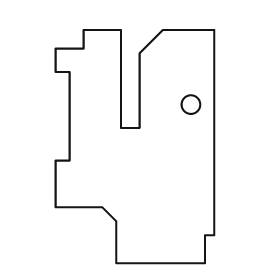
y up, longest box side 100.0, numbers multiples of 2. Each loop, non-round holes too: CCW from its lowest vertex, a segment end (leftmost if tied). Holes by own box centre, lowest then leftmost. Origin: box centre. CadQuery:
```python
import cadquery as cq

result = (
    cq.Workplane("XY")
    .moveTo(-8.0, -50.0)
    .lineTo(30.0, -50.0)
    .lineTo(30.0, -38.0)
    .lineTo(34.0, -38.0)
    .lineTo(34.0, 50.0)
    .lineTo(12.0, 50.0)
    .lineTo(2.0, 40.0)
    .lineTo(2.0, 8.0)
    .lineTo(-6.0, 8.0)
    .lineTo(-6.0, 50.0)
    .lineTo(-22.0, 50.0)
    .lineTo(-22.0, 42.0)
    .lineTo(-34.0, 42.0)
    .lineTo(-34.0, 32.0)
    .lineTo(-28.0, 32.0)
    .lineTo(-28.0, -6.0)
    .lineTo(-34.0, -6.0)
    .lineTo(-34.0, -26.0)
    .lineTo(-14.0, -26.0)
    .lineTo(-8.0, -32.0)
    .close()
    .moveTo(24.0, 18.0)
    .circle(4.0)
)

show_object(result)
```